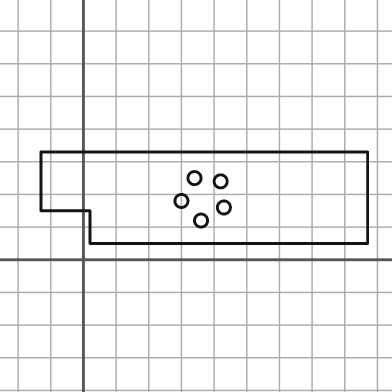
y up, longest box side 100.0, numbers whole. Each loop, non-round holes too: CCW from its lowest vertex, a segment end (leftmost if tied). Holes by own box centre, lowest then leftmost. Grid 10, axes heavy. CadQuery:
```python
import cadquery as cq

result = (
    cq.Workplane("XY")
    .moveTo(2.0, 5.0)
    .lineTo(87.0, 5.0)
    .lineTo(87.0, 33.0)
    .lineTo(-13.0, 33.0)
    .lineTo(-13.0, 15.0)
    .lineTo(2.0, 15.0)
    .close()
    .moveTo(36.0, 12.0)
    .circle(2.0)
    .moveTo(43.0, 16.0)
    .circle(2.0)
    .moveTo(30.0, 18.0)
    .circle(2.0)
    .moveTo(42.0, 24.0)
    .circle(2.0)
    .moveTo(34.0, 25.0)
    .circle(2.0)
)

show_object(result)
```